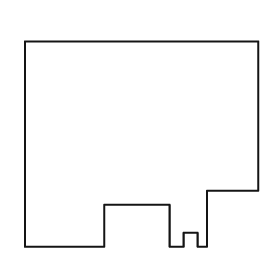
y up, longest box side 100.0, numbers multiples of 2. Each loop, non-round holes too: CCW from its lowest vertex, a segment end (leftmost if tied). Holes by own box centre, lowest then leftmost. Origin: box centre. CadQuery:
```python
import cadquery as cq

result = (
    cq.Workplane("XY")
    .moveTo(-50.0, -44.0)
    .lineTo(-16.0, -44.0)
    .lineTo(-16.0, -26.0)
    .lineTo(12.0, -26.0)
    .lineTo(12.0, -44.0)
    .lineTo(18.0, -44.0)
    .lineTo(18.0, -38.0)
    .lineTo(24.0, -38.0)
    .lineTo(24.0, -44.0)
    .lineTo(28.0, -44.0)
    .lineTo(28.0, -20.0)
    .lineTo(50.0, -20.0)
    .lineTo(50.0, 44.0)
    .lineTo(-50.0, 44.0)
    .close()
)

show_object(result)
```